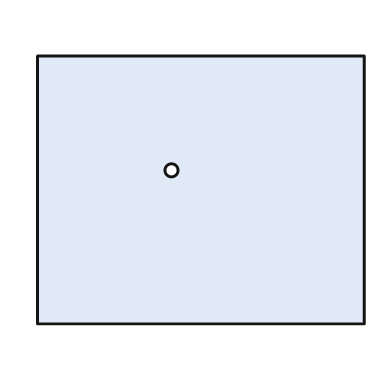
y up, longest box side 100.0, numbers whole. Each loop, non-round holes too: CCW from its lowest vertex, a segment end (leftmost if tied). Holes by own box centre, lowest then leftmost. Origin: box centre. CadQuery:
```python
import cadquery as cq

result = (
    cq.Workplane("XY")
    .moveTo(-50.0, -41.0)
    .lineTo(50.0, -41.0)
    .lineTo(50.0, 41.0)
    .lineTo(-50.0, 41.0)
    .close()
    .moveTo(-9.0, 6.0)
    .circle(2.0)
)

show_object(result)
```